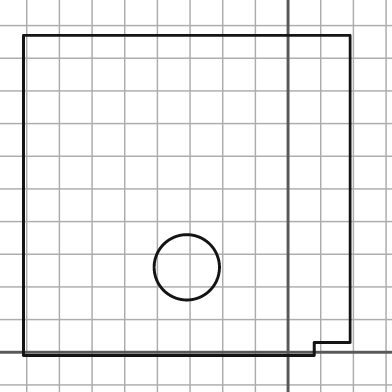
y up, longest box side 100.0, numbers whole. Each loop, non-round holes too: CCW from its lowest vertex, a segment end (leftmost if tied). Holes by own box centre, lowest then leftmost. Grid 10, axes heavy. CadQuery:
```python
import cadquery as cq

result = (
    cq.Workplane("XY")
    .moveTo(-81.0, -1.0)
    .lineTo(8.0, -1.0)
    .lineTo(8.0, 3.0)
    .lineTo(19.0, 3.0)
    .lineTo(19.0, 97.0)
    .lineTo(-81.0, 97.0)
    .close()
    .moveTo(-31.0, 26.0)
    .circle(10.0)
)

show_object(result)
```